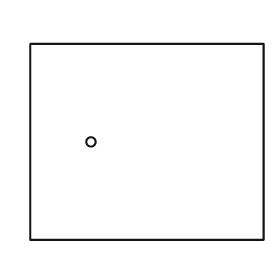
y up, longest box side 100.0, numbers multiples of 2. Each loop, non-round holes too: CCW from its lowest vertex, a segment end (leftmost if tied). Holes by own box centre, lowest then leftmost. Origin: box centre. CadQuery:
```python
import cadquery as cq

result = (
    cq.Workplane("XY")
    .moveTo(-50.0, -42.0)
    .lineTo(50.0, -42.0)
    .lineTo(50.0, 42.0)
    .lineTo(-50.0, 42.0)
    .close()
    .moveTo(-24.0, 0.0)
    .circle(2.0)
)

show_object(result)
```